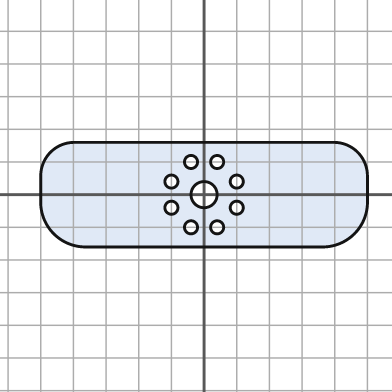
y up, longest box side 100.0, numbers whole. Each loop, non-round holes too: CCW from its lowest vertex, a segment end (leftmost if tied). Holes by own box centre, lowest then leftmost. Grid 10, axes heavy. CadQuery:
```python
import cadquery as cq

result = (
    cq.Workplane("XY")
    .moveTo(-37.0, -16.0)
    .lineTo(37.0, -16.0)
    .threePointArc((46.0, -12.0), (50.0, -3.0))
    .lineTo(50.0, 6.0)
    .threePointArc((47.0, 13.0), (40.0, 16.0))
    .lineTo(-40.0, 16.0)
    .threePointArc((-47.0, 13.0), (-50.0, 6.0))
    .lineTo(-50.0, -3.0)
    .threePointArc((-46.0, -12.0), (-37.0, -16.0))
    .close()
    .moveTo(-4.0, -10.0)
    .circle(2.0)
    .moveTo(4.0, -10.0)
    .circle(2.0)
    .moveTo(-10.0, -4.0)
    .circle(2.0)
    .moveTo(10.0, -4.0)
    .circle(2.0)
    .moveTo(0.0, 0.0)
    .circle(4.0)
    .moveTo(-10.0, 4.0)
    .circle(2.0)
    .moveTo(10.0, 4.0)
    .circle(2.0)
    .moveTo(-4.0, 10.0)
    .circle(2.0)
    .moveTo(4.0, 10.0)
    .circle(2.0)
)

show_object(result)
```